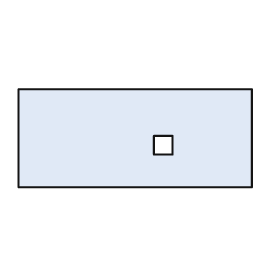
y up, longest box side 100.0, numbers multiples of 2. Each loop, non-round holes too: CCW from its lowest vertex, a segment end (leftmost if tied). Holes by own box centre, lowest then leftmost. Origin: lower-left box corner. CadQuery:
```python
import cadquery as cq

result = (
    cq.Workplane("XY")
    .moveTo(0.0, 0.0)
    .lineTo(100.0, 0.0)
    .lineTo(100.0, 42.0)
    .lineTo(0.0, 42.0)
    .close()
    .moveTo(58.0, 14.0)
    .lineTo(66.0, 14.0)
    .lineTo(66.0, 22.0)
    .lineTo(58.0, 22.0)
    .close()
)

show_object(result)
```